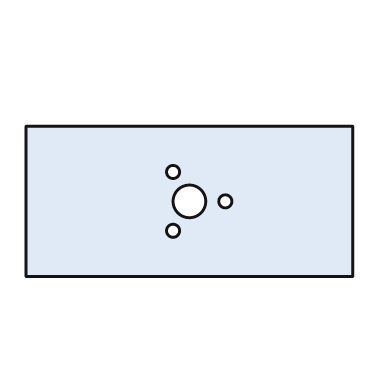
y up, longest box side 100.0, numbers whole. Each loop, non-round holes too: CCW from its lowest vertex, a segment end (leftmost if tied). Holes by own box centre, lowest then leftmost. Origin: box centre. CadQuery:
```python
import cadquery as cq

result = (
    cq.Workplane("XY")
    .moveTo(-50.0, -23.0)
    .lineTo(50.0, -23.0)
    .lineTo(50.0, 23.0)
    .lineTo(-50.0, 23.0)
    .close()
    .moveTo(-5.0, -9.0)
    .circle(2.0)
    .moveTo(0.0, 0.0)
    .circle(5.0)
    .moveTo(11.0, 0.0)
    .circle(2.0)
    .moveTo(-5.0, 9.0)
    .circle(2.0)
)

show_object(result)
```